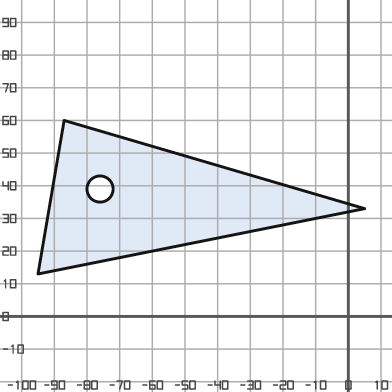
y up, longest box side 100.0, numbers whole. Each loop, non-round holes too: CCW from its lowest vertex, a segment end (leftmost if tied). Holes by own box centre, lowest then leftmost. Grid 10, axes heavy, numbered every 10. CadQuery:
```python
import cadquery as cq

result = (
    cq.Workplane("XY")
    .moveTo(-95.0, 13.0)
    .lineTo(5.0, 33.0)
    .lineTo(-87.0, 60.0)
    .close()
    .moveTo(-76.0, 39.0)
    .circle(4.0)
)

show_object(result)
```